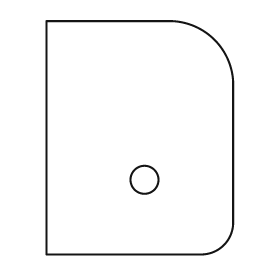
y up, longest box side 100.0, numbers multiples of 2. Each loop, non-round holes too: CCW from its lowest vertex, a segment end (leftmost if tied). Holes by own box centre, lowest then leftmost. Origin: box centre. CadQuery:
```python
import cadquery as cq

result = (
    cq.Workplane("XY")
    .moveTo(-40.0, -50.0)
    .lineTo(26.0, -50.0)
    .threePointArc((36.0, -46.0), (40.0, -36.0))
    .lineTo(40.0, 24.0)
    .threePointArc((32.0, 42.0), (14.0, 50.0))
    .lineTo(-40.0, 50.0)
    .close()
    .moveTo(2.0, -18.0)
    .circle(6.0)
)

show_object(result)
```